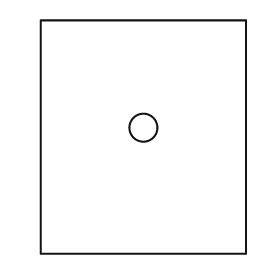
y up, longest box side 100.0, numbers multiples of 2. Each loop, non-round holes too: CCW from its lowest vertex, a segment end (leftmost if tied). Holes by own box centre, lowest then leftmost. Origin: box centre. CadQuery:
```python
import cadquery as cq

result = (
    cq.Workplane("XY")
    .moveTo(-44.0, -50.0)
    .lineTo(44.0, -50.0)
    .lineTo(44.0, 50.0)
    .lineTo(-44.0, 50.0)
    .close()
    .moveTo(0.0, 4.0)
    .circle(6.0)
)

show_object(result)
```